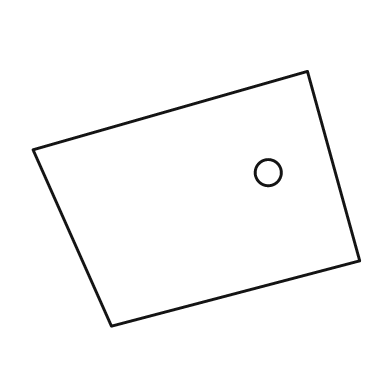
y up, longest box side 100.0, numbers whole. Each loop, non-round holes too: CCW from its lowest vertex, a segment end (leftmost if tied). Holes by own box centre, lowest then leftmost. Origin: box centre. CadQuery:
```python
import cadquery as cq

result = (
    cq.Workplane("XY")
    .moveTo(-26.0, -39.0)
    .lineTo(50.0, -19.0)
    .lineTo(34.0, 39.0)
    .lineTo(-50.0, 15.0)
    .close()
    .moveTo(22.0, 8.0)
    .circle(4.0)
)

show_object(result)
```